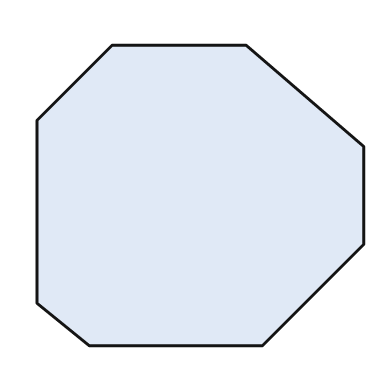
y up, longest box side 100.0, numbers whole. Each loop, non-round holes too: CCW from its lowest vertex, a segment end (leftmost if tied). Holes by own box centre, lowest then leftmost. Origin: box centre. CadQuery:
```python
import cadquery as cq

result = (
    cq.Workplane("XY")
    .moveTo(-34.0, -46.0)
    .lineTo(19.0, -46.0)
    .lineTo(50.0, -15.0)
    .lineTo(50.0, 15.0)
    .lineTo(14.0, 46.0)
    .lineTo(-27.0, 46.0)
    .lineTo(-50.0, 23.0)
    .lineTo(-50.0, -33.0)
    .close()
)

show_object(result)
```